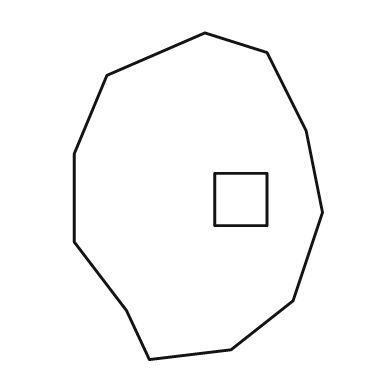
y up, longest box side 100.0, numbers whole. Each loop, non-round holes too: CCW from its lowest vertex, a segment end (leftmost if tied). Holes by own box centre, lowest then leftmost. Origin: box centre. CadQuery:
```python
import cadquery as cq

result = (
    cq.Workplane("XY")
    .moveTo(-15.0, -50.0)
    .lineTo(10.0, -47.0)
    .lineTo(29.0, -32.0)
    .lineTo(38.0, -5.0)
    .lineTo(33.0, 20.0)
    .lineTo(21.0, 44.0)
    .lineTo(2.0, 50.0)
    .lineTo(-28.0, 37.0)
    .lineTo(-38.0, 13.0)
    .lineTo(-38.0, -14.0)
    .lineTo(-22.0, -35.0)
    .close()
    .moveTo(5.0, -9.0)
    .lineTo(21.0, -9.0)
    .lineTo(21.0, 7.0)
    .lineTo(5.0, 7.0)
    .close()
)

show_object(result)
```